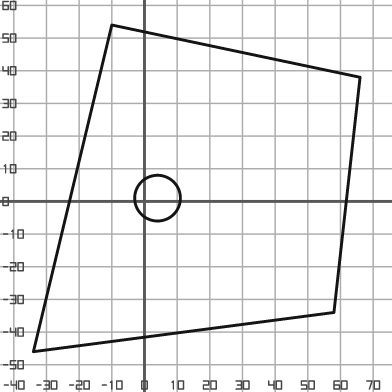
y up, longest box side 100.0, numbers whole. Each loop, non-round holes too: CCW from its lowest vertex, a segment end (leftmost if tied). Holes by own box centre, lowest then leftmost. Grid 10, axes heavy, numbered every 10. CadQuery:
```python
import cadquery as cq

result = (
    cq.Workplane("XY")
    .moveTo(-34.0, -46.0)
    .lineTo(58.0, -34.0)
    .lineTo(66.0, 38.0)
    .lineTo(-10.0, 54.0)
    .close()
    .moveTo(4.0, 1.0)
    .circle(7.0)
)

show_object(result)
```